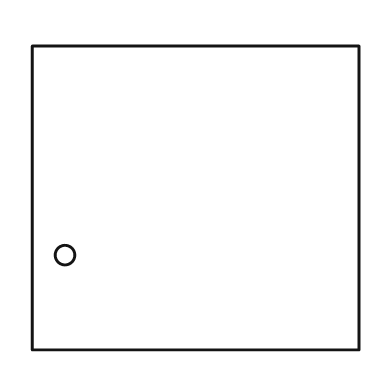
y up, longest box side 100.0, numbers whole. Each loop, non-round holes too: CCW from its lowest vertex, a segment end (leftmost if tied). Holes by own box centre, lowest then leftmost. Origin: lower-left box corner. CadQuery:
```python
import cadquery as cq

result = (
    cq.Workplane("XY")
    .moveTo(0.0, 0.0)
    .lineTo(100.0, 0.0)
    .lineTo(100.0, 93.0)
    .lineTo(0.0, 93.0)
    .close()
    .moveTo(10.0, 29.0)
    .circle(3.0)
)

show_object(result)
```